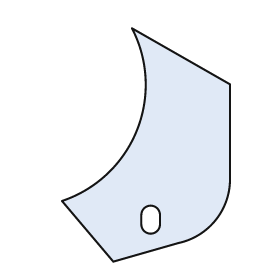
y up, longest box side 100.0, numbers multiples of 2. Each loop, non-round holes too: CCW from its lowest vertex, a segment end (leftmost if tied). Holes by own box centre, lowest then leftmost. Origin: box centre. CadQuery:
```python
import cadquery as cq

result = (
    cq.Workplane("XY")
    .moveTo(-14.0, -50.0)
    .lineTo(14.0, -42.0)
    .threePointArc((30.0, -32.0), (36.0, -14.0))
    .lineTo(36.0, 26.0)
    .lineTo(-6.0, 50.0)
    .threePointArc((-4.0, 6.0), (-36.0, -24.0))
    .close()
    .moveTo(-2.0, -34.0)
    .threePointArc((2.0, -38.0), (6.0, -34.0))
    .lineTo(6.0, -30.0)
    .threePointArc((2.0, -26.0), (-2.0, -30.0))
    .close()
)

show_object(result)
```